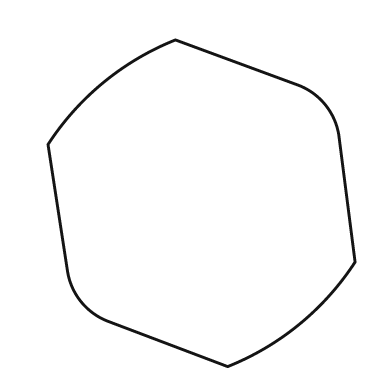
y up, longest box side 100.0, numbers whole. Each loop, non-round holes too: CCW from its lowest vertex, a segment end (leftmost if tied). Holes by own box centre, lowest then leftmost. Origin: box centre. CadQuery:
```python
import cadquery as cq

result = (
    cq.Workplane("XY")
    .moveTo(8.0, -50.0)
    .threePointArc((30.0, -37.0), (47.0, -18.0))
    .lineTo(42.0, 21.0)
    .threePointArc((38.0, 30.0), (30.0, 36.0))
    .lineTo(-8.0, 50.0)
    .threePointArc((-30.0, 37.0), (-47.0, 18.0))
    .lineTo(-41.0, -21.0)
    .threePointArc((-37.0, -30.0), (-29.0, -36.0))
    .close()
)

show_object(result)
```